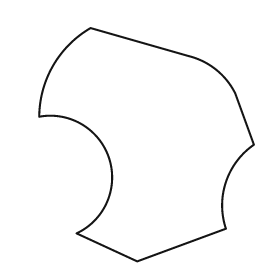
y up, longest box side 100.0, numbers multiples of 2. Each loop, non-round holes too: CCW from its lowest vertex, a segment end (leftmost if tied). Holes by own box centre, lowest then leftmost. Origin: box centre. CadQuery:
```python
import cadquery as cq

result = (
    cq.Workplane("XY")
    .moveTo(-4.0, -50.0)
    .lineTo(34.0, -36.0)
    .threePointArc((34.0, -16.0), (46.0, 0.0))
    .lineTo(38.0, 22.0)
    .threePointArc((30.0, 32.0), (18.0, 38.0))
    .lineTo(-24.0, 50.0)
    .threePointArc((-40.0, 34.0), (-46.0, 12.0))
    .threePointArc((-16.0, -6.0), (-30.0, -38.0))
    .close()
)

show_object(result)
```